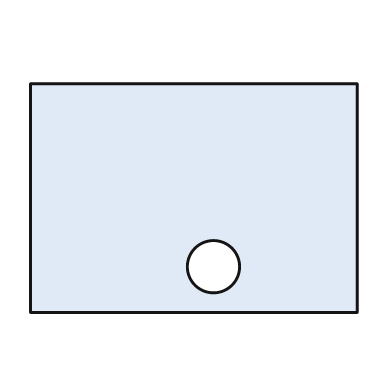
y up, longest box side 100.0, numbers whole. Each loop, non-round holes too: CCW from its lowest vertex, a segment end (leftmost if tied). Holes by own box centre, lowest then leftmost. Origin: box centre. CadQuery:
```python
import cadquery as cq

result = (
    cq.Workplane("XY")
    .moveTo(-50.0, -35.0)
    .lineTo(50.0, -35.0)
    .lineTo(50.0, 35.0)
    .lineTo(-50.0, 35.0)
    .close()
    .moveTo(6.0, -21.0)
    .circle(8.0)
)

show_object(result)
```